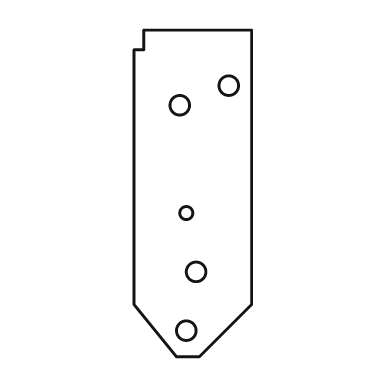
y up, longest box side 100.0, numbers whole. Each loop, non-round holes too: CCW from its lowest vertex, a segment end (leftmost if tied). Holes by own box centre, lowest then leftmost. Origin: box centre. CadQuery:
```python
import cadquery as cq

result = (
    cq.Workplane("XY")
    .moveTo(-5.0, -50.0)
    .lineTo(2.0, -50.0)
    .lineTo(18.0, -34.0)
    .lineTo(18.0, 50.0)
    .lineTo(-15.0, 50.0)
    .lineTo(-15.0, 44.0)
    .lineTo(-18.0, 44.0)
    .lineTo(-18.0, -34.0)
    .close()
    .moveTo(-2.0, -42.0)
    .circle(3.0)
    .moveTo(1.0, -24.0)
    .circle(3.0)
    .moveTo(-2.0, -6.0)
    .circle(2.0)
    .moveTo(-4.0, 27.0)
    .circle(3.0)
    .moveTo(11.0, 33.0)
    .circle(3.0)
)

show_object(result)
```